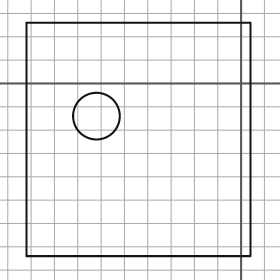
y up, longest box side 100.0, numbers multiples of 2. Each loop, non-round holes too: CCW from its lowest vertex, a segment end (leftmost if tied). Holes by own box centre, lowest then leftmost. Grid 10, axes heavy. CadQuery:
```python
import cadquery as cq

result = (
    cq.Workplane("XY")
    .moveTo(-92.0, -74.0)
    .lineTo(4.0, -74.0)
    .lineTo(4.0, 26.0)
    .lineTo(-92.0, 26.0)
    .close()
    .moveTo(-62.0, -14.0)
    .circle(10.0)
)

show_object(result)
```